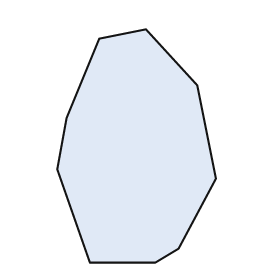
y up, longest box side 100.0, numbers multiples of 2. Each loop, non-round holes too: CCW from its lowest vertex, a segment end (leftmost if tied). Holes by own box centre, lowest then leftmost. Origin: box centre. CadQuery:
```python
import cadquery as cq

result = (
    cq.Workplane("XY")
    .moveTo(-20.0, -50.0)
    .lineTo(8.0, -50.0)
    .lineTo(18.0, -44.0)
    .lineTo(34.0, -14.0)
    .lineTo(26.0, 26.0)
    .lineTo(4.0, 50.0)
    .lineTo(-16.0, 46.0)
    .lineTo(-30.0, 12.0)
    .lineTo(-34.0, -10.0)
    .close()
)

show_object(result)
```